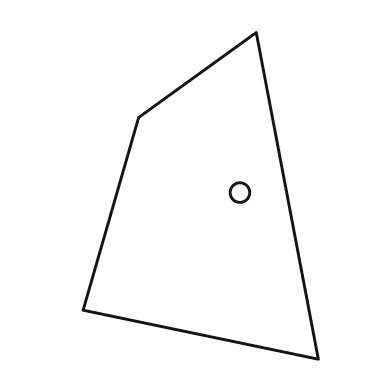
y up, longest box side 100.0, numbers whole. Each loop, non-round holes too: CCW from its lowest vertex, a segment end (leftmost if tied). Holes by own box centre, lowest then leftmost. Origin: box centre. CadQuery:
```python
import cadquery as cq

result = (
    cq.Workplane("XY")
    .moveTo(36.0, -50.0)
    .lineTo(17.0, 50.0)
    .lineTo(-19.0, 24.0)
    .lineTo(-36.0, -35.0)
    .close()
    .moveTo(12.0, 1.0)
    .circle(3.0)
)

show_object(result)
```